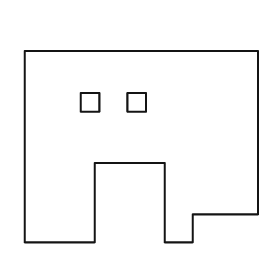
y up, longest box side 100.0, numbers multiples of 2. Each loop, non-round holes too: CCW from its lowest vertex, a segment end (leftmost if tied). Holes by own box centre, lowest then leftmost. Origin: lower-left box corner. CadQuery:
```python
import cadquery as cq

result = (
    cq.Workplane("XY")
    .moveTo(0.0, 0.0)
    .lineTo(30.0, 0.0)
    .lineTo(30.0, 34.0)
    .lineTo(60.0, 34.0)
    .lineTo(60.0, 0.0)
    .lineTo(72.0, 0.0)
    .lineTo(72.0, 12.0)
    .lineTo(100.0, 12.0)
    .lineTo(100.0, 82.0)
    .lineTo(0.0, 82.0)
    .close()
    .moveTo(24.0, 56.0)
    .lineTo(32.0, 56.0)
    .lineTo(32.0, 64.0)
    .lineTo(24.0, 64.0)
    .close()
    .moveTo(44.0, 56.0)
    .lineTo(52.0, 56.0)
    .lineTo(52.0, 64.0)
    .lineTo(44.0, 64.0)
    .close()
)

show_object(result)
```